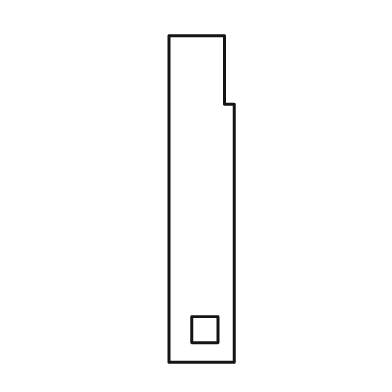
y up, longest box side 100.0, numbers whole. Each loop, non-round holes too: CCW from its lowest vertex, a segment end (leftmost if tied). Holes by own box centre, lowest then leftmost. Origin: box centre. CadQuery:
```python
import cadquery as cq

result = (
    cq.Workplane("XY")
    .moveTo(-10.0, -50.0)
    .lineTo(10.0, -50.0)
    .lineTo(10.0, 29.0)
    .lineTo(7.0, 29.0)
    .lineTo(7.0, 50.0)
    .lineTo(-10.0, 50.0)
    .close()
    .moveTo(-3.0, -44.0)
    .lineTo(5.0, -44.0)
    .lineTo(5.0, -36.0)
    .lineTo(-3.0, -36.0)
    .close()
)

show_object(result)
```